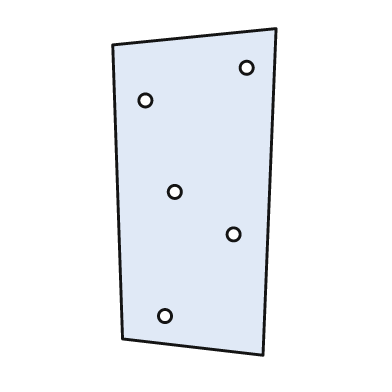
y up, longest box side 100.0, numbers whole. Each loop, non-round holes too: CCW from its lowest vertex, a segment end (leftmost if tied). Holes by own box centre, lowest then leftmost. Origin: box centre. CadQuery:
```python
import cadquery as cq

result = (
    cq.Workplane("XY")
    .moveTo(21.0, -50.0)
    .lineTo(25.0, 50.0)
    .lineTo(-25.0, 45.0)
    .lineTo(-22.0, -45.0)
    .close()
    .moveTo(-9.0, -38.0)
    .circle(2.0)
    .moveTo(12.0, -13.0)
    .circle(2.0)
    .moveTo(-6.0, 0.0)
    .circle(2.0)
    .moveTo(-15.0, 28.0)
    .circle(2.0)
    .moveTo(16.0, 38.0)
    .circle(2.0)
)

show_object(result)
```